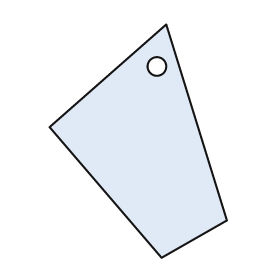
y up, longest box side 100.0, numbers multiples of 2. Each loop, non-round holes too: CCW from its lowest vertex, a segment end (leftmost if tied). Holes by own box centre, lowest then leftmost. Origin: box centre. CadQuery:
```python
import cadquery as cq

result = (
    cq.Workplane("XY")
    .moveTo(10.0, -50.0)
    .lineTo(38.0, -34.0)
    .lineTo(12.0, 50.0)
    .lineTo(-38.0, 6.0)
    .close()
    .moveTo(8.0, 32.0)
    .circle(4.0)
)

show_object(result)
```